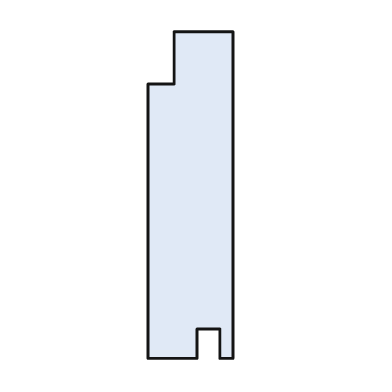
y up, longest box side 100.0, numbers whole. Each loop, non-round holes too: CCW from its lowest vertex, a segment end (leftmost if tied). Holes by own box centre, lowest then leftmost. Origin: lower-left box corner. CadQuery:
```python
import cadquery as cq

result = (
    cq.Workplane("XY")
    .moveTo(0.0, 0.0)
    .lineTo(15.0, 0.0)
    .lineTo(15.0, 9.0)
    .lineTo(22.0, 9.0)
    .lineTo(22.0, 0.0)
    .lineTo(26.0, 0.0)
    .lineTo(26.0, 100.0)
    .lineTo(8.0, 100.0)
    .lineTo(8.0, 84.0)
    .lineTo(0.0, 84.0)
    .close()
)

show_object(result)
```